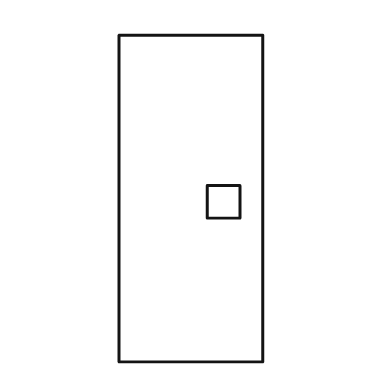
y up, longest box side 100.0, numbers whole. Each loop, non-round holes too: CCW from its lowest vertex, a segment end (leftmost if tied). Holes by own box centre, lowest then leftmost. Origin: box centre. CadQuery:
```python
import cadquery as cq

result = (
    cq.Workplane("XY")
    .moveTo(-22.0, -50.0)
    .lineTo(22.0, -50.0)
    .lineTo(22.0, 50.0)
    .lineTo(-22.0, 50.0)
    .close()
    .moveTo(5.0, -6.0)
    .lineTo(15.0, -6.0)
    .lineTo(15.0, 4.0)
    .lineTo(5.0, 4.0)
    .close()
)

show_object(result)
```